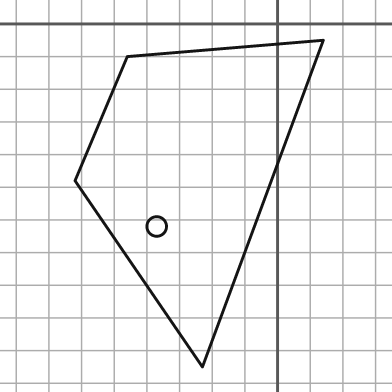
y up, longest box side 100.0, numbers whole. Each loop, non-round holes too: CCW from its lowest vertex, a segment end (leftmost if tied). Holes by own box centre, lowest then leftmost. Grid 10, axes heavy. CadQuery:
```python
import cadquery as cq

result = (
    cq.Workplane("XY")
    .moveTo(-23.0, -105.0)
    .lineTo(14.0, -5.0)
    .lineTo(-46.0, -10.0)
    .lineTo(-62.0, -48.0)
    .close()
    .moveTo(-37.0, -62.0)
    .circle(3.0)
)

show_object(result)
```